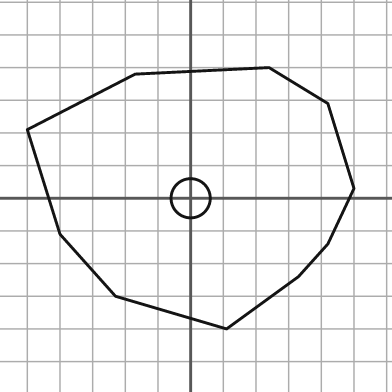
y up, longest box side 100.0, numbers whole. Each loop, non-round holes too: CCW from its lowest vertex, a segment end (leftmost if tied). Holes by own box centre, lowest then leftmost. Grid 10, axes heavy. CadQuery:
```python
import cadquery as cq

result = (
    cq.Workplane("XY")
    .moveTo(11.0, -40.0)
    .lineTo(33.0, -24.0)
    .lineTo(42.0, -14.0)
    .lineTo(50.0, 3.0)
    .lineTo(42.0, 29.0)
    .lineTo(24.0, 40.0)
    .lineTo(-17.0, 38.0)
    .lineTo(-50.0, 21.0)
    .lineTo(-40.0, -11.0)
    .lineTo(-23.0, -30.0)
    .close()
    .moveTo(0.0, 0.0)
    .circle(6.0)
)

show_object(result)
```